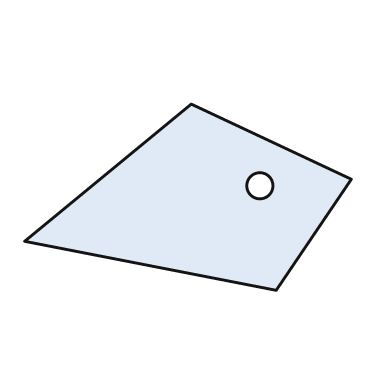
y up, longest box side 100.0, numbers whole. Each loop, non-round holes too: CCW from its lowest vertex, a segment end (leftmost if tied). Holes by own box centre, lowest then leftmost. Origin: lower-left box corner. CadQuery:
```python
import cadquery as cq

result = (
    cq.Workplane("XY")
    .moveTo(77.0, 0.0)
    .lineTo(100.0, 34.0)
    .lineTo(51.0, 57.0)
    .lineTo(0.0, 15.0)
    .close()
    .moveTo(72.0, 32.0)
    .circle(4.0)
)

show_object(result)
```